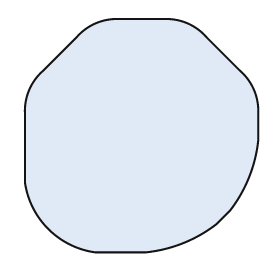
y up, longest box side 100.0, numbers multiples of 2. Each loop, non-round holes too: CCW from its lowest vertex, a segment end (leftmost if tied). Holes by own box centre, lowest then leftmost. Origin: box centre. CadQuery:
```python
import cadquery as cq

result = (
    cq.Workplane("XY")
    .moveTo(-20.0, -50.0)
    .lineTo(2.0, -50.0)
    .threePointArc((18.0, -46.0), (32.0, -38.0))
    .lineTo(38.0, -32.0)
    .threePointArc((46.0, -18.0), (50.0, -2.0))
    .lineTo(50.0, 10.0)
    .threePointArc((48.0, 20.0), (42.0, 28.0))
    .lineTo(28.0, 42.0)
    .threePointArc((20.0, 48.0), (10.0, 50.0))
    .lineTo(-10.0, 50.0)
    .threePointArc((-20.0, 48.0), (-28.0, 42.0))
    .lineTo(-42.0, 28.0)
    .threePointArc((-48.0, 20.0), (-50.0, 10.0))
    .lineTo(-50.0, -20.0)
    .threePointArc((-40.0, -40.0), (-20.0, -50.0))
    .close()
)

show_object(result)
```